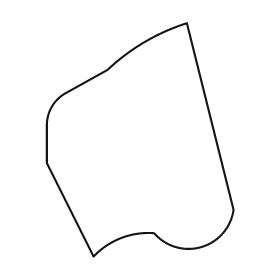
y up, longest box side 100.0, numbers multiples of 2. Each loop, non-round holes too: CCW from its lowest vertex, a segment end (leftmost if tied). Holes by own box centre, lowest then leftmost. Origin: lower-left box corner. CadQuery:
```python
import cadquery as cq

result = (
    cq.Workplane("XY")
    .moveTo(20.0, 0.0)
    .threePointArc((32.0, 8.0), (46.0, 10.0))
    .threePointArc((66.0, 4.0), (80.0, 20.0))
    .lineTo(60.0, 100.0)
    .threePointArc((42.0, 92.0), (26.0, 80.0))
    .lineTo(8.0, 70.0)
    .threePointArc((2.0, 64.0), (0.0, 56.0))
    .lineTo(0.0, 40.0)
    .close()
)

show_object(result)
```